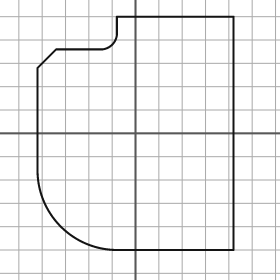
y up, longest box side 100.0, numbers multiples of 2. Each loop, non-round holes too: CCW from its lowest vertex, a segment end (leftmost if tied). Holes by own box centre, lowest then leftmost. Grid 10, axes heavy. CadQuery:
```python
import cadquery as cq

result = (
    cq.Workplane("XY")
    .moveTo(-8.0, -50.0)
    .lineTo(42.0, -50.0)
    .lineTo(42.0, 50.0)
    .lineTo(-8.0, 50.0)
    .lineTo(-8.0, 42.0)
    .threePointArc((-10.0, 38.0), (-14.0, 36.0))
    .lineTo(-34.0, 36.0)
    .lineTo(-42.0, 28.0)
    .lineTo(-42.0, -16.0)
    .threePointArc((-32.0, -40.0), (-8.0, -50.0))
    .close()
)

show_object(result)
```